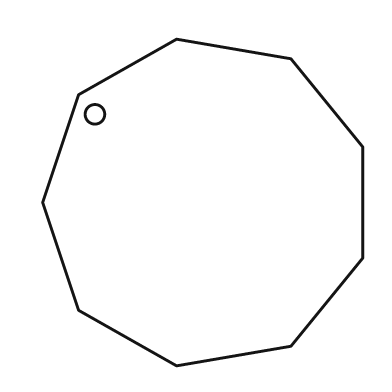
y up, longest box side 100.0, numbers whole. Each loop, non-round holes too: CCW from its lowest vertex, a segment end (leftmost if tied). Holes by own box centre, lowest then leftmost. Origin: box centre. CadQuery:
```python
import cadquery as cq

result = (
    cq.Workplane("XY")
    .moveTo(-8.0, -50.0)
    .lineTo(27.0, -44.0)
    .lineTo(49.0, -17.0)
    .lineTo(49.0, 17.0)
    .lineTo(27.0, 44.0)
    .lineTo(-8.0, 50.0)
    .lineTo(-38.0, 33.0)
    .lineTo(-49.0, 0.0)
    .lineTo(-38.0, -33.0)
    .close()
    .moveTo(-33.0, 27.0)
    .circle(3.0)
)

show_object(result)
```